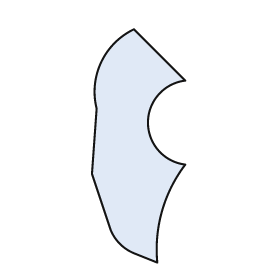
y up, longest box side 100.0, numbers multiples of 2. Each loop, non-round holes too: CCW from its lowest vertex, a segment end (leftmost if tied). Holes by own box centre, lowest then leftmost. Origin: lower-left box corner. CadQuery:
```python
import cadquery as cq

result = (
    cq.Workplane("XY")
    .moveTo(28.0, 0.0)
    .threePointArc((30.0, 22.0), (40.0, 42.0))
    .threePointArc((24.0, 60.0), (40.0, 78.0))
    .lineTo(18.0, 100.0)
    .threePointArc((4.0, 86.0), (2.0, 66.0))
    .lineTo(0.0, 38.0)
    .lineTo(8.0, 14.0)
    .threePointArc((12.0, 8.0), (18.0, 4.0))
    .close()
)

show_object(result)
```